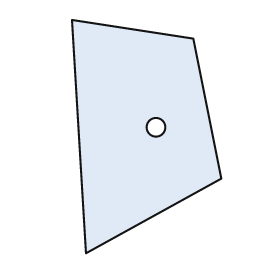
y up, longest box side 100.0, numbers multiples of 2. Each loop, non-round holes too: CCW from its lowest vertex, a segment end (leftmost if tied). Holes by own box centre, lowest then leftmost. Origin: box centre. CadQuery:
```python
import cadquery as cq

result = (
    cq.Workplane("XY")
    .moveTo(-26.0, -50.0)
    .lineTo(32.0, -18.0)
    .lineTo(20.0, 42.0)
    .lineTo(-32.0, 50.0)
    .close()
    .moveTo(4.0, 4.0)
    .circle(4.0)
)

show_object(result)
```